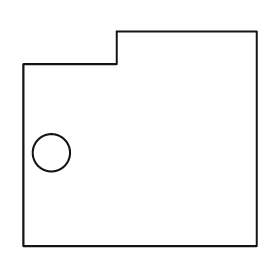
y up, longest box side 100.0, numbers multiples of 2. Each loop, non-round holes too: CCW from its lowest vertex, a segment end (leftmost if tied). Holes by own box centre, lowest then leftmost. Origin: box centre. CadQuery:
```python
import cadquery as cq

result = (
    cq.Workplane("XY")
    .moveTo(-50.0, -46.0)
    .lineTo(50.0, -46.0)
    .lineTo(50.0, 46.0)
    .lineTo(-10.0, 46.0)
    .lineTo(-10.0, 32.0)
    .lineTo(-50.0, 32.0)
    .close()
    .moveTo(-38.0, -6.0)
    .circle(8.0)
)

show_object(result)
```